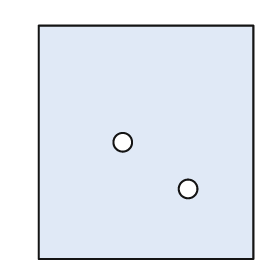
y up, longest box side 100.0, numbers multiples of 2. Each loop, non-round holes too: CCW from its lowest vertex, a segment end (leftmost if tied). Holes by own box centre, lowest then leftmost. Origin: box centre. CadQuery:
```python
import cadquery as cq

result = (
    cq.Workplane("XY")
    .moveTo(-46.0, -50.0)
    .lineTo(46.0, -50.0)
    .lineTo(46.0, 50.0)
    .lineTo(-46.0, 50.0)
    .close()
    .moveTo(18.0, -20.0)
    .circle(4.0)
    .moveTo(-10.0, 0.0)
    .circle(4.0)
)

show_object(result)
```